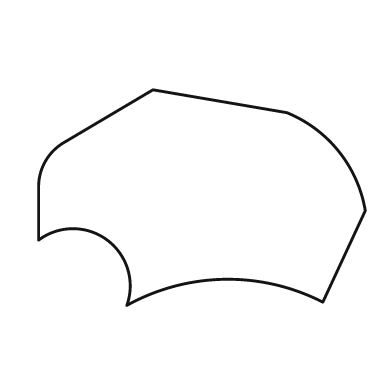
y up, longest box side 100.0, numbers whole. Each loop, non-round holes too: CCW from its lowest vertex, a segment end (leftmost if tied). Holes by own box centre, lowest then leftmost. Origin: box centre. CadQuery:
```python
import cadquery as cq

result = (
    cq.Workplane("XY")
    .moveTo(-23.0, -33.0)
    .threePointArc((7.0, -25.0), (37.0, -32.0))
    .lineTo(50.0, -4.0)
    .threePointArc((42.0, 14.0), (26.0, 26.0))
    .lineTo(-15.0, 33.0)
    .lineTo(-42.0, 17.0)
    .threePointArc((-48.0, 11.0), (-50.0, 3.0))
    .lineTo(-50.0, -13.0)
    .threePointArc((-29.0, -13.0), (-23.0, -33.0))
    .close()
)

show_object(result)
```